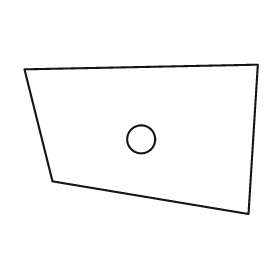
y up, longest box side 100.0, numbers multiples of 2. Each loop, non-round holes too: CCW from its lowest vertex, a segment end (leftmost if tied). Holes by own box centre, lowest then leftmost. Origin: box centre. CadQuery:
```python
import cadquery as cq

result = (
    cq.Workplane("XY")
    .moveTo(46.0, -32.0)
    .lineTo(50.0, 32.0)
    .lineTo(-50.0, 30.0)
    .lineTo(-38.0, -18.0)
    .close()
    .moveTo(0.0, 0.0)
    .circle(6.0)
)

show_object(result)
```